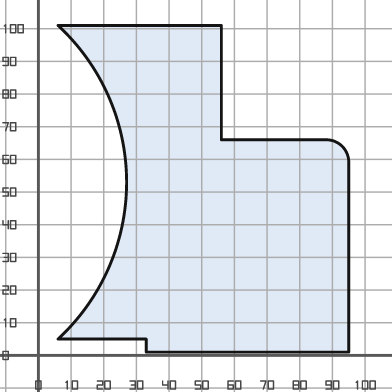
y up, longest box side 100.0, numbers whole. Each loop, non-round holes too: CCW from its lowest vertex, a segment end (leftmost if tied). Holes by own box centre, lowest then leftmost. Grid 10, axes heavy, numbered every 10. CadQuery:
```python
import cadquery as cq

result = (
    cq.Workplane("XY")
    .moveTo(33.0, 1.0)
    .lineTo(95.0, 1.0)
    .lineTo(95.0, 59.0)
    .threePointArc((93.0, 64.0), (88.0, 66.0))
    .lineTo(56.0, 66.0)
    .lineTo(56.0, 101.0)
    .lineTo(6.0, 101.0)
    .threePointArc((27.0, 53.0), (6.0, 5.0))
    .lineTo(33.0, 5.0)
    .close()
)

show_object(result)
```